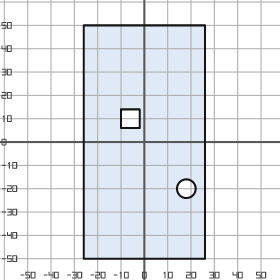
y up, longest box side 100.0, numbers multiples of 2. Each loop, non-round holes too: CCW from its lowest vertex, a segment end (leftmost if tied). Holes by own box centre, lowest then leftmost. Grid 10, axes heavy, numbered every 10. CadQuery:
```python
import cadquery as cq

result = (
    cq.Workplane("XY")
    .moveTo(-26.0, -50.0)
    .lineTo(26.0, -50.0)
    .lineTo(26.0, 50.0)
    .lineTo(-26.0, 50.0)
    .close()
    .moveTo(18.0, -20.0)
    .circle(4.0)
    .moveTo(-10.0, 6.0)
    .lineTo(-2.0, 6.0)
    .lineTo(-2.0, 14.0)
    .lineTo(-10.0, 14.0)
    .close()
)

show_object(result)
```